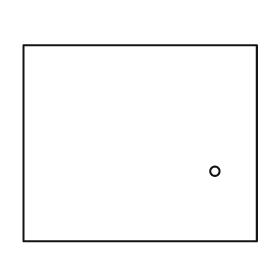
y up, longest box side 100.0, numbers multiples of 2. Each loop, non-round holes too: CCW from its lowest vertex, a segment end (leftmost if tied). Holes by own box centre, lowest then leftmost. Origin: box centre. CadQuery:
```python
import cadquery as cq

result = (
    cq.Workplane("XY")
    .moveTo(-50.0, -42.0)
    .lineTo(50.0, -42.0)
    .lineTo(50.0, 42.0)
    .lineTo(-50.0, 42.0)
    .close()
    .moveTo(32.0, -12.0)
    .circle(2.0)
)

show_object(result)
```